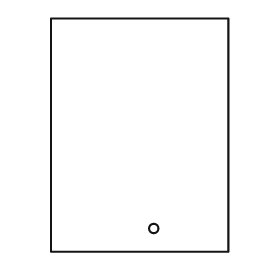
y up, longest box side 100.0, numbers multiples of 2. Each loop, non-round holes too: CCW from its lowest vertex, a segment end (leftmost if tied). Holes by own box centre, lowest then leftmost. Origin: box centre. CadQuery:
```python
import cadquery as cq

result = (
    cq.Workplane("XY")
    .moveTo(-38.0, -50.0)
    .lineTo(38.0, -50.0)
    .lineTo(38.0, 50.0)
    .lineTo(-38.0, 50.0)
    .close()
    .moveTo(6.0, -40.0)
    .circle(2.0)
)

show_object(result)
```